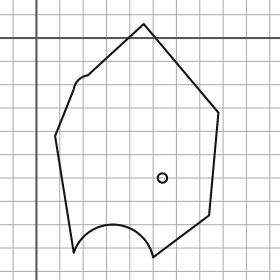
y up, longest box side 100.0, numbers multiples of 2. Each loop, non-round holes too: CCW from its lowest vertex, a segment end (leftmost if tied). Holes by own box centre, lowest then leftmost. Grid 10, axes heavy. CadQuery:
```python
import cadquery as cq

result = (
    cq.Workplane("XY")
    .moveTo(50.0, -94.0)
    .lineTo(74.0, -76.0)
    .lineTo(78.0, -32.0)
    .lineTo(46.0, 6.0)
    .lineTo(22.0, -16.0)
    .threePointArc((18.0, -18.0), (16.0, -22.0))
    .lineTo(8.0, -42.0)
    .lineTo(16.0, -92.0)
    .threePointArc((34.0, -80.0), (50.0, -94.0))
    .close()
    .moveTo(54.0, -60.0)
    .circle(2.0)
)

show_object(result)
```